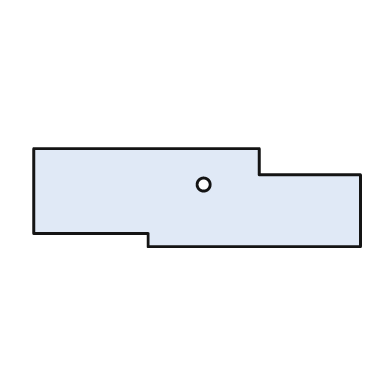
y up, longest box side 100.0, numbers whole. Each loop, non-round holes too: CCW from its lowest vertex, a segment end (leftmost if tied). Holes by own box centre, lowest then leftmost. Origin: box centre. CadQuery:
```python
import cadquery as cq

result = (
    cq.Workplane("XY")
    .moveTo(-15.0, -15.0)
    .lineTo(50.0, -15.0)
    .lineTo(50.0, 7.0)
    .lineTo(19.0, 7.0)
    .lineTo(19.0, 15.0)
    .lineTo(-50.0, 15.0)
    .lineTo(-50.0, -11.0)
    .lineTo(-15.0, -11.0)
    .close()
    .moveTo(2.0, 4.0)
    .circle(2.0)
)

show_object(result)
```